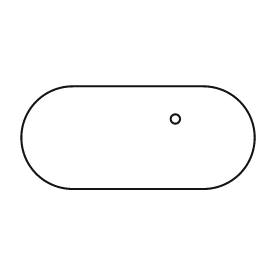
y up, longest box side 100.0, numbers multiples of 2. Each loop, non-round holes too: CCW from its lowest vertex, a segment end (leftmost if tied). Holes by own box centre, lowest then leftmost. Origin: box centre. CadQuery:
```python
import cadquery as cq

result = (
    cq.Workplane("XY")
    .moveTo(-28.0, -22.0)
    .lineTo(28.0, -22.0)
    .threePointArc((50.0, 0.0), (28.0, 22.0))
    .lineTo(-28.0, 22.0)
    .threePointArc((-50.0, 0.0), (-28.0, -22.0))
    .close()
    .moveTo(16.0, 8.0)
    .circle(2.0)
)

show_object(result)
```